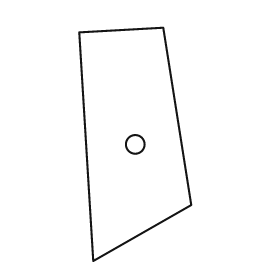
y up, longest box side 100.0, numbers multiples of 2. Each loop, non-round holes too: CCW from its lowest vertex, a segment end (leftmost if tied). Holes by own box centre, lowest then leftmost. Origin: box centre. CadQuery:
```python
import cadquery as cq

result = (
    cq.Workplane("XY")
    .moveTo(-18.0, -50.0)
    .lineTo(24.0, -26.0)
    .lineTo(12.0, 50.0)
    .lineTo(-24.0, 48.0)
    .close()
    .moveTo(0.0, 0.0)
    .circle(4.0)
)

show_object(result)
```